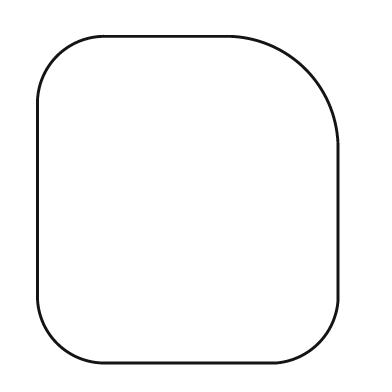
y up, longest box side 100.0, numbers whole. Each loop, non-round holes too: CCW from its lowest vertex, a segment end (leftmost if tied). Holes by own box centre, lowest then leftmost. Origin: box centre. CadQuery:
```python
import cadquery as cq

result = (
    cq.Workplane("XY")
    .moveTo(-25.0, -50.0)
    .lineTo(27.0, -50.0)
    .threePointArc((40.0, -44.0), (46.0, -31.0))
    .lineTo(46.0, 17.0)
    .threePointArc((36.0, 40.0), (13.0, 50.0))
    .lineTo(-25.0, 50.0)
    .threePointArc((-40.0, 44.0), (-46.0, 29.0))
    .lineTo(-46.0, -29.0)
    .threePointArc((-40.0, -44.0), (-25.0, -50.0))
    .close()
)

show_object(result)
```